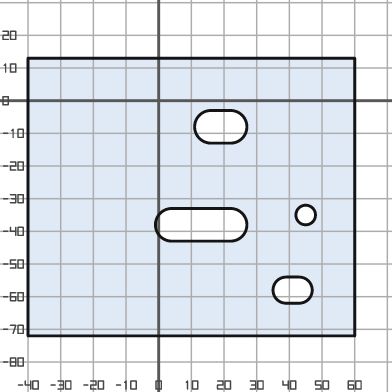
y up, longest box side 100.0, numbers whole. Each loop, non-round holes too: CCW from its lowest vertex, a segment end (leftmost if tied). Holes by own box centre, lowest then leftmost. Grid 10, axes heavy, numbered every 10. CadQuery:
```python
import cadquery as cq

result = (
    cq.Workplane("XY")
    .moveTo(-40.0, -72.0)
    .lineTo(60.0, -72.0)
    .lineTo(60.0, 13.0)
    .lineTo(-40.0, 13.0)
    .close()
    .moveTo(39.0, -62.0)
    .lineTo(43.0, -62.0)
    .threePointArc((47.0, -58.0), (43.0, -54.0))
    .lineTo(39.0, -54.0)
    .threePointArc((35.0, -58.0), (39.0, -62.0))
    .close()
    .moveTo(4.0, -43.0)
    .lineTo(22.0, -43.0)
    .threePointArc((27.0, -38.0), (22.0, -33.0))
    .lineTo(4.0, -33.0)
    .threePointArc((-1.0, -38.0), (4.0, -43.0))
    .close()
    .moveTo(45.0, -35.0)
    .circle(3.0)
    .moveTo(16.0, -13.0)
    .lineTo(22.0, -13.0)
    .threePointArc((27.0, -8.0), (22.0, -3.0))
    .lineTo(16.0, -3.0)
    .threePointArc((11.0, -8.0), (16.0, -13.0))
    .close()
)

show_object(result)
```